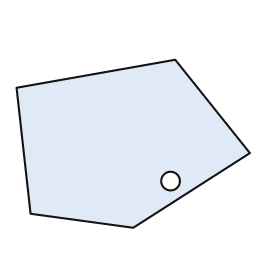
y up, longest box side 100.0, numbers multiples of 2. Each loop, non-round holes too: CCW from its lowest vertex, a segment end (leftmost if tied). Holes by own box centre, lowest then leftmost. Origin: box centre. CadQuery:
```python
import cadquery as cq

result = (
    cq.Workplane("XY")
    .moveTo(0.0, -36.0)
    .lineTo(50.0, -4.0)
    .lineTo(18.0, 36.0)
    .lineTo(-50.0, 24.0)
    .lineTo(-44.0, -30.0)
    .close()
    .moveTo(16.0, -16.0)
    .circle(4.0)
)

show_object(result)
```